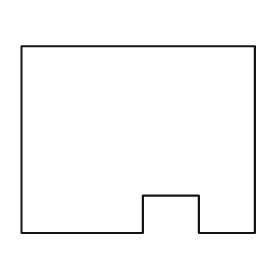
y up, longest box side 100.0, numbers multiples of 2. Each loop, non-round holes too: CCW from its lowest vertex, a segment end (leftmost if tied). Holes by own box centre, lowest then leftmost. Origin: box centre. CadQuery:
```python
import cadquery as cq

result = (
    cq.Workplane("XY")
    .moveTo(-50.0, -40.0)
    .lineTo(2.0, -40.0)
    .lineTo(2.0, -24.0)
    .lineTo(26.0, -24.0)
    .lineTo(26.0, -40.0)
    .lineTo(50.0, -40.0)
    .lineTo(50.0, 40.0)
    .lineTo(-50.0, 40.0)
    .close()
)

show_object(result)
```